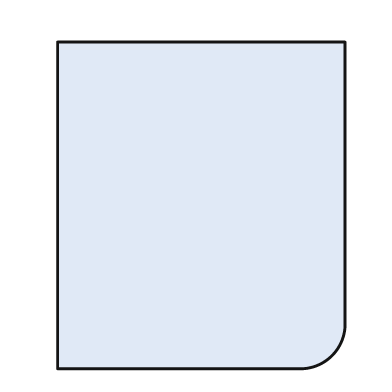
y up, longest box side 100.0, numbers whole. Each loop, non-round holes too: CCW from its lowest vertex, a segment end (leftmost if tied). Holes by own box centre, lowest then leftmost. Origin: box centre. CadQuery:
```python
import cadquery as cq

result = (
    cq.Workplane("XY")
    .moveTo(-44.0, -50.0)
    .lineTo(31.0, -50.0)
    .threePointArc((40.0, -46.0), (44.0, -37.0))
    .lineTo(44.0, 50.0)
    .lineTo(-44.0, 50.0)
    .close()
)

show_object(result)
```